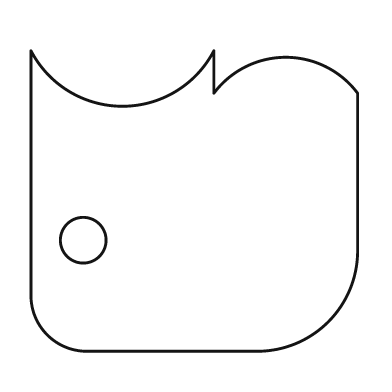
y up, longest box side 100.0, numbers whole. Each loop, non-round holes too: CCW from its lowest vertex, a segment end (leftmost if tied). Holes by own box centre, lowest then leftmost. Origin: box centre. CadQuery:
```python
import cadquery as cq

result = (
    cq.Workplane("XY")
    .moveTo(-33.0, -46.0)
    .lineTo(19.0, -46.0)
    .threePointArc((41.0, -37.0), (50.0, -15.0))
    .lineTo(50.0, 33.0)
    .threePointArc((28.0, 44.0), (6.0, 33.0))
    .lineTo(6.0, 46.0)
    .threePointArc((-22.0, 29.0), (-50.0, 46.0))
    .lineTo(-50.0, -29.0)
    .threePointArc((-45.0, -41.0), (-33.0, -46.0))
    .close()
    .moveTo(-34.0, -12.0)
    .circle(7.0)
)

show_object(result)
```